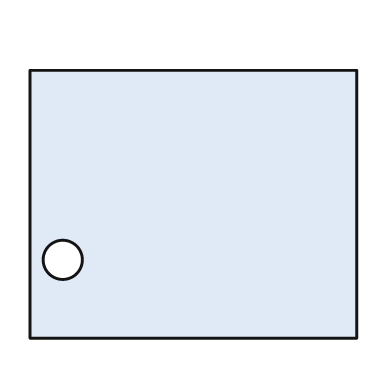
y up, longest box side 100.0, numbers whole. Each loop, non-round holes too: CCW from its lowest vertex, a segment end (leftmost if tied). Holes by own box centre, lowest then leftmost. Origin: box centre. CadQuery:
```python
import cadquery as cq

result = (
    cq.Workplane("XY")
    .moveTo(-50.0, -41.0)
    .lineTo(50.0, -41.0)
    .lineTo(50.0, 41.0)
    .lineTo(-50.0, 41.0)
    .close()
    .moveTo(-40.0, -17.0)
    .circle(6.0)
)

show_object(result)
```